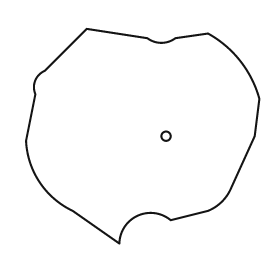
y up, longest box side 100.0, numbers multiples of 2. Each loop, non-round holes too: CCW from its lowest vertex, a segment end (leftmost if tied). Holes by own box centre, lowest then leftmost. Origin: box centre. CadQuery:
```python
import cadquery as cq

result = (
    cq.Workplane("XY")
    .moveTo(-10.0, -46.0)
    .threePointArc((-2.0, -34.0), (12.0, -36.0))
    .lineTo(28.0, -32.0)
    .threePointArc((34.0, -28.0), (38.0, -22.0))
    .lineTo(48.0, 0.0)
    .lineTo(50.0, 16.0)
    .threePointArc((42.0, 32.0), (28.0, 44.0))
    .lineTo(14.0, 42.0)
    .threePointArc((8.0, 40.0), (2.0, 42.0))
    .lineTo(-24.0, 46.0)
    .lineTo(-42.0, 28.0)
    .threePointArc((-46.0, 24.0), (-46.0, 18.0))
    .lineTo(-50.0, -2.0)
    .threePointArc((-44.0, -20.0), (-30.0, -32.0))
    .close()
    .moveTo(10.0, 0.0)
    .circle(2.0)
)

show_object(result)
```